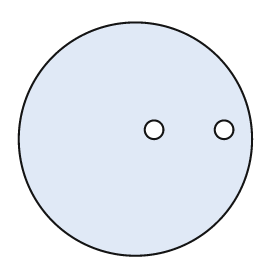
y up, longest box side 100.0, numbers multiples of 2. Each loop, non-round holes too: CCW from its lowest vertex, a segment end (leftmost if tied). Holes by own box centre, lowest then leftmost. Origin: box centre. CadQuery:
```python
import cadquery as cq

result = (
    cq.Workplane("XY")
    .moveTo(0.0, 0.0)
    .circle(50.0)
    .moveTo(8.0, 4.0)
    .circle(4.0)
    .moveTo(38.0, 4.0)
    .circle(4.0)
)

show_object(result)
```